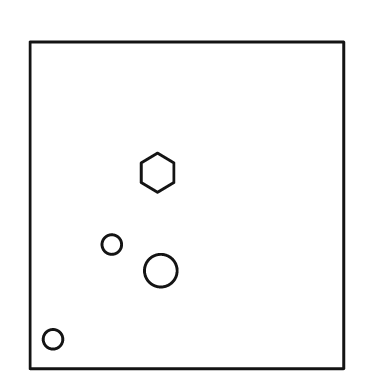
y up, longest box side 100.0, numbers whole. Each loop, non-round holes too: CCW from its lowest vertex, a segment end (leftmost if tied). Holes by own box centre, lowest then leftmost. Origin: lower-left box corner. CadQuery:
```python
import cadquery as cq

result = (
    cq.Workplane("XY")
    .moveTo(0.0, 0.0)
    .lineTo(96.0, 0.0)
    .lineTo(96.0, 100.0)
    .lineTo(0.0, 100.0)
    .close()
    .moveTo(7.0, 9.0)
    .circle(3.0)
    .moveTo(40.0, 30.0)
    .circle(5.0)
    .moveTo(25.0, 38.0)
    .circle(3.0)
    .moveTo(39.0, 54.0)
    .lineTo(44.0, 57.0)
    .lineTo(44.0, 63.0)
    .lineTo(39.0, 66.0)
    .lineTo(34.0, 63.0)
    .lineTo(34.0, 57.0)
    .close()
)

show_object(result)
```